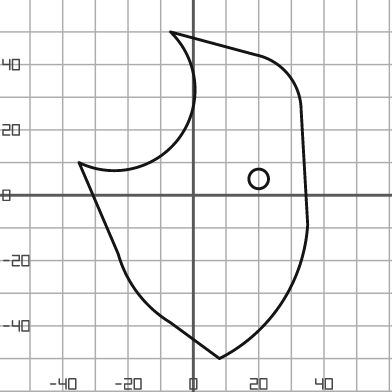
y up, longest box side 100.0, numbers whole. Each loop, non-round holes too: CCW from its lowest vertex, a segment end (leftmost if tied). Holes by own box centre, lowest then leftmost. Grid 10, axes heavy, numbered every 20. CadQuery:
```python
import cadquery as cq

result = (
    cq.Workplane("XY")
    .moveTo(8.0, -50.0)
    .threePointArc((27.0, -33.0), (35.0, -9.0))
    .lineTo(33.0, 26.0)
    .threePointArc((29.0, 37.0), (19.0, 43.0))
    .lineTo(-7.0, 50.0)
    .threePointArc((-4.0, 18.0), (-35.0, 10.0))
    .lineTo(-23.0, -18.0)
    .threePointArc((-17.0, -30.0), (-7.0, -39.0))
    .close()
    .moveTo(20.0, 5.0)
    .circle(3.0)
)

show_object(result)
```